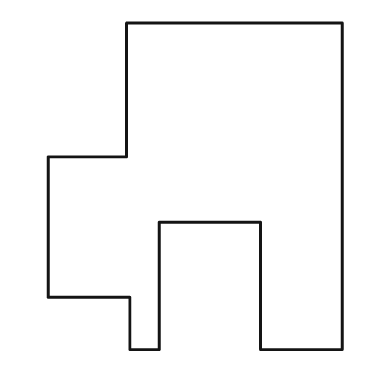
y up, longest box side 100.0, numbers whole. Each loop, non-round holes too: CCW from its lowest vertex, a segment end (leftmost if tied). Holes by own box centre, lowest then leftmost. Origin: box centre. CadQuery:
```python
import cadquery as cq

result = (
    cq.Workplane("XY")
    .moveTo(-20.0, -50.0)
    .lineTo(-11.0, -50.0)
    .lineTo(-11.0, -11.0)
    .lineTo(20.0, -11.0)
    .lineTo(20.0, -50.0)
    .lineTo(45.0, -50.0)
    .lineTo(45.0, 50.0)
    .lineTo(-21.0, 50.0)
    .lineTo(-21.0, 9.0)
    .lineTo(-45.0, 9.0)
    .lineTo(-45.0, -34.0)
    .lineTo(-20.0, -34.0)
    .close()
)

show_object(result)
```